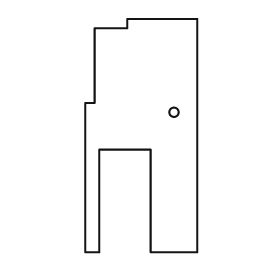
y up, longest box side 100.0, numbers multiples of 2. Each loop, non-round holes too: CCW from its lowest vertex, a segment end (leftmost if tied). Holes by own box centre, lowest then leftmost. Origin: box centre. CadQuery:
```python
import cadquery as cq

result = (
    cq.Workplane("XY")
    .moveTo(-24.0, -50.0)
    .lineTo(-18.0, -50.0)
    .lineTo(-18.0, -6.0)
    .lineTo(4.0, -6.0)
    .lineTo(4.0, -50.0)
    .lineTo(24.0, -50.0)
    .lineTo(24.0, 50.0)
    .lineTo(-6.0, 50.0)
    .lineTo(-6.0, 46.0)
    .lineTo(-20.0, 46.0)
    .lineTo(-20.0, 14.0)
    .lineTo(-24.0, 14.0)
    .close()
    .moveTo(14.0, 10.0)
    .circle(2.0)
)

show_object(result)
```